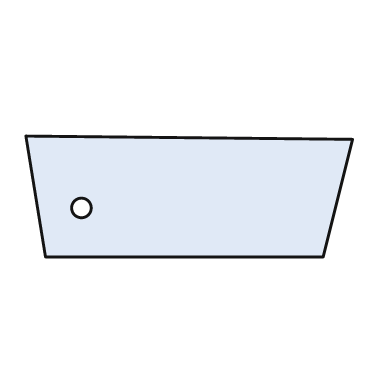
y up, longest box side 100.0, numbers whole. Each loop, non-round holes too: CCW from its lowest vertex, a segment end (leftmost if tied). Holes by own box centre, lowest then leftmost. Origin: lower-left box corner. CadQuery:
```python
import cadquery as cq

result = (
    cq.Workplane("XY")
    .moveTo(6.0, 0.0)
    .lineTo(91.0, 0.0)
    .lineTo(100.0, 36.0)
    .lineTo(0.0, 37.0)
    .close()
    .moveTo(17.0, 15.0)
    .circle(3.0)
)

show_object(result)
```